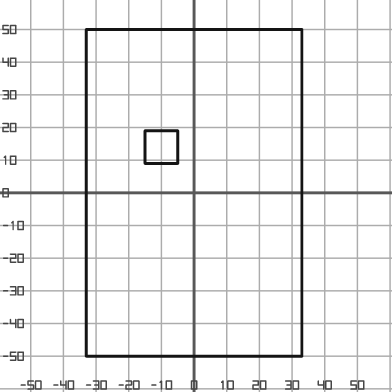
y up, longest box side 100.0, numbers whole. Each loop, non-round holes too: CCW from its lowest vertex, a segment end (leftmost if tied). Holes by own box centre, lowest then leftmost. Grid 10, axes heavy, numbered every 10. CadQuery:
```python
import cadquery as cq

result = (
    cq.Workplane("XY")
    .moveTo(-33.0, -50.0)
    .lineTo(33.0, -50.0)
    .lineTo(33.0, 50.0)
    .lineTo(-33.0, 50.0)
    .close()
    .moveTo(-15.0, 9.0)
    .lineTo(-5.0, 9.0)
    .lineTo(-5.0, 19.0)
    .lineTo(-15.0, 19.0)
    .close()
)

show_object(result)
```